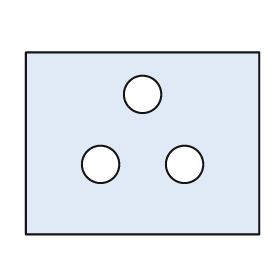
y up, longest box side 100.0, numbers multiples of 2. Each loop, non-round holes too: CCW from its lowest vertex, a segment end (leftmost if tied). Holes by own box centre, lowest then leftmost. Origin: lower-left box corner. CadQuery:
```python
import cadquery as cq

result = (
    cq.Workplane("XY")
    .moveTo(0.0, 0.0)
    .lineTo(100.0, 0.0)
    .lineTo(100.0, 78.0)
    .lineTo(0.0, 78.0)
    .close()
    .moveTo(32.0, 30.0)
    .circle(8.0)
    .moveTo(68.0, 30.0)
    .circle(8.0)
    .moveTo(50.0, 60.0)
    .circle(8.0)
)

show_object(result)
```